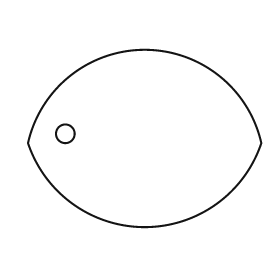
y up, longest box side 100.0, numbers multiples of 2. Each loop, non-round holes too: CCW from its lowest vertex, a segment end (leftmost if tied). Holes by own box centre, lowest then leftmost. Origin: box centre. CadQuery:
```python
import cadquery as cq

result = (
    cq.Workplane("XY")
    .moveTo(-50.0, -2.0)
    .threePointArc((0.0, -38.0), (50.0, -2.0))
    .threePointArc((0.0, 38.0), (-50.0, -2.0))
    .close()
    .moveTo(-34.0, 2.0)
    .circle(4.0)
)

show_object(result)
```